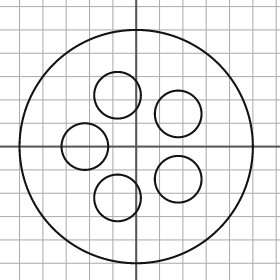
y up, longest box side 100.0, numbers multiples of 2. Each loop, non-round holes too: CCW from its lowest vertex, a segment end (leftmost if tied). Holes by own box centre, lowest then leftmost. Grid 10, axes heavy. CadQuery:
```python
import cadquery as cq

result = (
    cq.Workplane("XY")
    .moveTo(0.0, 0.0)
    .circle(50.0)
    .moveTo(-8.0, -22.0)
    .circle(10.0)
    .moveTo(18.0, -14.0)
    .circle(10.0)
    .moveTo(-22.0, 0.0)
    .circle(10.0)
    .moveTo(18.0, 14.0)
    .circle(10.0)
    .moveTo(-8.0, 22.0)
    .circle(10.0)
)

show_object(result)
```